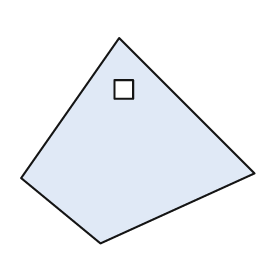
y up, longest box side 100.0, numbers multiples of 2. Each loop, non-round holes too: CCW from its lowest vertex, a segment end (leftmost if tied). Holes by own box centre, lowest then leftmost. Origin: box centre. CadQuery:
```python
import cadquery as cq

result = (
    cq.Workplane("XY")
    .moveTo(-16.0, -44.0)
    .lineTo(50.0, -14.0)
    .lineTo(-8.0, 44.0)
    .lineTo(-50.0, -16.0)
    .close()
    .moveTo(-10.0, 18.0)
    .lineTo(-2.0, 18.0)
    .lineTo(-2.0, 26.0)
    .lineTo(-10.0, 26.0)
    .close()
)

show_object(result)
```